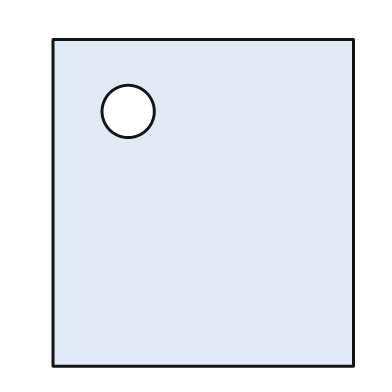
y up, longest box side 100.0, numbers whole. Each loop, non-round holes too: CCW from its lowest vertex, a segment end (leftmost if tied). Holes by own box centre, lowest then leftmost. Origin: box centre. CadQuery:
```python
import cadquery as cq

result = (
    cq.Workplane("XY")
    .moveTo(-46.0, -50.0)
    .lineTo(46.0, -50.0)
    .lineTo(46.0, 50.0)
    .lineTo(-46.0, 50.0)
    .close()
    .moveTo(-23.0, 28.0)
    .circle(8.0)
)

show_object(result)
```